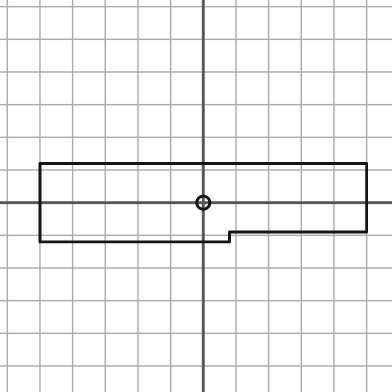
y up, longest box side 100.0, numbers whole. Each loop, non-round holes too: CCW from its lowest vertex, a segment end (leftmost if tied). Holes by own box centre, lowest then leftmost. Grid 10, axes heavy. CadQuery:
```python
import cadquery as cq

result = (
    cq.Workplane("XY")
    .moveTo(-50.0, -12.0)
    .lineTo(8.0, -12.0)
    .lineTo(8.0, -9.0)
    .lineTo(50.0, -9.0)
    .lineTo(50.0, 12.0)
    .lineTo(-50.0, 12.0)
    .close()
    .moveTo(0.0, 0.0)
    .circle(2.0)
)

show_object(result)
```